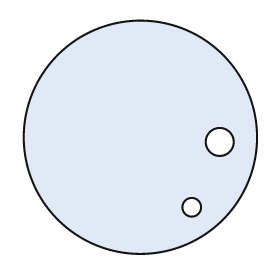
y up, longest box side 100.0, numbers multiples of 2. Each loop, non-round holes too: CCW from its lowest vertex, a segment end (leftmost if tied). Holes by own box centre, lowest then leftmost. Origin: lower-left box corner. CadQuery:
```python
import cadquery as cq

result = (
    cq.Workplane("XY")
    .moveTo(50.0, 50.0)
    .circle(50.0)
    .moveTo(72.0, 20.0)
    .circle(4.0)
    .moveTo(84.0, 48.0)
    .circle(6.0)
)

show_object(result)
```